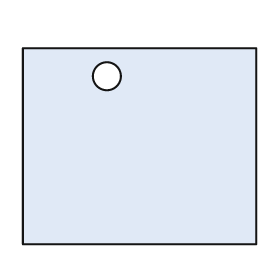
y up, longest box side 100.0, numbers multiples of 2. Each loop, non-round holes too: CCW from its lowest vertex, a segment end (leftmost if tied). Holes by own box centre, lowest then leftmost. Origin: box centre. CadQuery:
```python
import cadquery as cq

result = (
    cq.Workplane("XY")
    .moveTo(-50.0, -42.0)
    .lineTo(50.0, -42.0)
    .lineTo(50.0, 42.0)
    .lineTo(-50.0, 42.0)
    .close()
    .moveTo(-14.0, 30.0)
    .circle(6.0)
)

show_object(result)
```